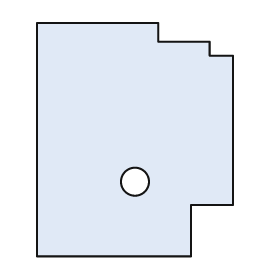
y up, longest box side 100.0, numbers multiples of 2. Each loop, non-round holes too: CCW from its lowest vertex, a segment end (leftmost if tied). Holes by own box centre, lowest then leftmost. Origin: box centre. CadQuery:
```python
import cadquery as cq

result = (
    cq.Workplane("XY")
    .moveTo(-42.0, -50.0)
    .lineTo(24.0, -50.0)
    .lineTo(24.0, -28.0)
    .lineTo(42.0, -28.0)
    .lineTo(42.0, 36.0)
    .lineTo(32.0, 36.0)
    .lineTo(32.0, 42.0)
    .lineTo(10.0, 42.0)
    .lineTo(10.0, 50.0)
    .lineTo(-42.0, 50.0)
    .close()
    .moveTo(0.0, -18.0)
    .circle(6.0)
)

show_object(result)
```